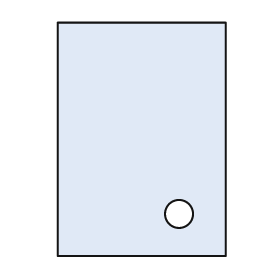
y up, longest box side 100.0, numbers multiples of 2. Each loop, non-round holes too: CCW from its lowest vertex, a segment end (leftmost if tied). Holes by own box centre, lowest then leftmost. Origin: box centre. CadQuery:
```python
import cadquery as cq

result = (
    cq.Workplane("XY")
    .moveTo(-36.0, -50.0)
    .lineTo(36.0, -50.0)
    .lineTo(36.0, 50.0)
    .lineTo(-36.0, 50.0)
    .close()
    .moveTo(16.0, -32.0)
    .circle(6.0)
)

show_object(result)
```